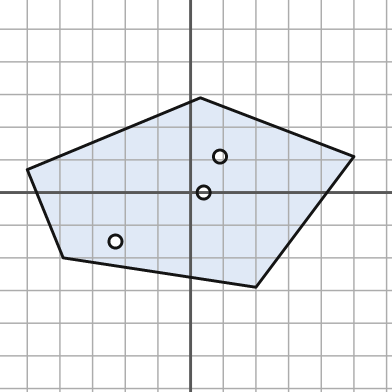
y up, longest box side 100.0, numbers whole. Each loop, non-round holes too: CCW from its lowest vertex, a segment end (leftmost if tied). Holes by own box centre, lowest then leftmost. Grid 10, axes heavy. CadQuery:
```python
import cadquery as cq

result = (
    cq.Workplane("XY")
    .moveTo(20.0, -29.0)
    .lineTo(50.0, 11.0)
    .lineTo(3.0, 29.0)
    .lineTo(-50.0, 7.0)
    .lineTo(-39.0, -20.0)
    .close()
    .moveTo(-23.0, -15.0)
    .circle(2.0)
    .moveTo(4.0, 0.0)
    .circle(2.0)
    .moveTo(9.0, 11.0)
    .circle(2.0)
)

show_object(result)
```